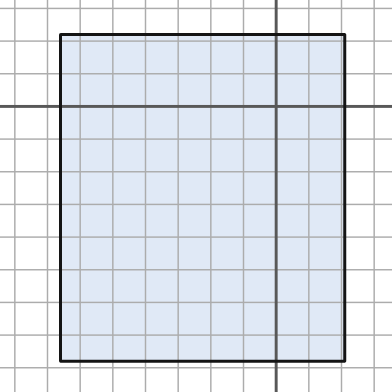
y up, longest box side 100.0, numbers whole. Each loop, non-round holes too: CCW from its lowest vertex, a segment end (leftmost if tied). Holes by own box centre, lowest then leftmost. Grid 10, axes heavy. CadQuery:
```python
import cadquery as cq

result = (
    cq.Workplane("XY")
    .moveTo(-66.0, -78.0)
    .lineTo(21.0, -78.0)
    .lineTo(21.0, 22.0)
    .lineTo(-66.0, 22.0)
    .close()
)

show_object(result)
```